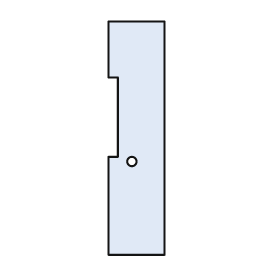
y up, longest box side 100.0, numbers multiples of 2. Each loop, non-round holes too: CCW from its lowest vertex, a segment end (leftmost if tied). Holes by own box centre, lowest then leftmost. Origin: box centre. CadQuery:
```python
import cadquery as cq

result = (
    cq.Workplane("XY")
    .moveTo(-12.0, -50.0)
    .lineTo(12.0, -50.0)
    .lineTo(12.0, 50.0)
    .lineTo(-12.0, 50.0)
    .lineTo(-12.0, 26.0)
    .lineTo(-8.0, 26.0)
    .lineTo(-8.0, -8.0)
    .lineTo(-12.0, -8.0)
    .close()
    .moveTo(-2.0, -10.0)
    .circle(2.0)
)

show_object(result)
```